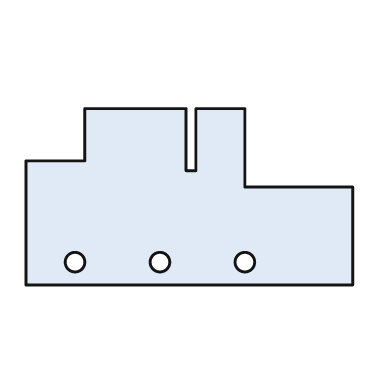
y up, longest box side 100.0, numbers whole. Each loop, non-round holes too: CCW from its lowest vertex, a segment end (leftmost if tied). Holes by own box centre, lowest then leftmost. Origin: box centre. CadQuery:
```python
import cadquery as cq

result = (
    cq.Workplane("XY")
    .moveTo(-50.0, -27.0)
    .lineTo(50.0, -27.0)
    .lineTo(50.0, 3.0)
    .lineTo(17.0, 3.0)
    .lineTo(17.0, 27.0)
    .lineTo(2.0, 27.0)
    .lineTo(2.0, 8.0)
    .lineTo(-1.0, 8.0)
    .lineTo(-1.0, 27.0)
    .lineTo(-32.0, 27.0)
    .lineTo(-32.0, 11.0)
    .lineTo(-50.0, 11.0)
    .close()
    .moveTo(-35.0, -20.0)
    .circle(3.0)
    .moveTo(-9.0, -20.0)
    .circle(3.0)
    .moveTo(17.0, -20.0)
    .circle(3.0)
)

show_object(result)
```